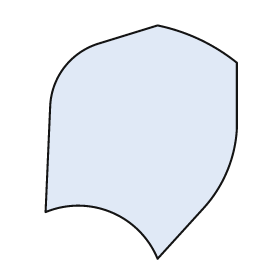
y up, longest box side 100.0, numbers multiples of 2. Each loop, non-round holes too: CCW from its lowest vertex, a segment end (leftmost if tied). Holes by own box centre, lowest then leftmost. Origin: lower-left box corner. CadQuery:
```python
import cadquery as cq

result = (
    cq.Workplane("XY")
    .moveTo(48.0, 0.0)
    .lineTo(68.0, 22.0)
    .threePointArc((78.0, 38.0), (82.0, 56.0))
    .lineTo(82.0, 84.0)
    .threePointArc((66.0, 94.0), (48.0, 100.0))
    .lineTo(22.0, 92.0)
    .threePointArc((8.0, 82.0), (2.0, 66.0))
    .lineTo(0.0, 20.0)
    .threePointArc((28.0, 20.0), (48.0, 0.0))
    .close()
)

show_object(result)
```